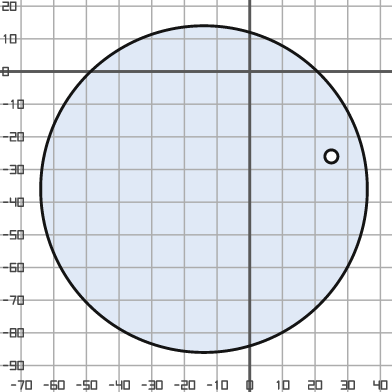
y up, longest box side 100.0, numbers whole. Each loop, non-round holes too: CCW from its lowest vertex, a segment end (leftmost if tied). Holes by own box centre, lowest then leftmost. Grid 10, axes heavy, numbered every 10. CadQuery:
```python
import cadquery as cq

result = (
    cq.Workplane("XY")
    .moveTo(-14.0, -36.0)
    .circle(50.0)
    .moveTo(25.0, -26.0)
    .circle(2.0)
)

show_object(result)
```